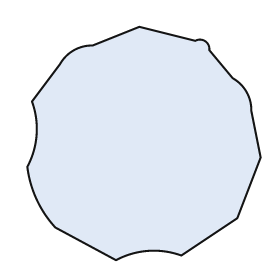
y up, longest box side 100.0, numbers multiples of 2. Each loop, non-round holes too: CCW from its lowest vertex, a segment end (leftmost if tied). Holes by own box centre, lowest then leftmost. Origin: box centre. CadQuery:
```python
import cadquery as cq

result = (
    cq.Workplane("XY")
    .moveTo(-12.0, -50.0)
    .threePointArc((2.0, -46.0), (16.0, -48.0))
    .lineTo(40.0, -32.0)
    .lineTo(50.0, -6.0)
    .lineTo(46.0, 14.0)
    .threePointArc((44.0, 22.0), (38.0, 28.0))
    .lineTo(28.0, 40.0)
    .threePointArc((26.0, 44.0), (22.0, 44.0))
    .lineTo(-2.0, 50.0)
    .lineTo(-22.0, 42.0)
    .threePointArc((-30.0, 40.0), (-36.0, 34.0))
    .lineTo(-48.0, 18.0)
    .threePointArc((-46.0, 4.0), (-50.0, -10.0))
    .threePointArc((-46.0, -24.0), (-38.0, -36.0))
    .close()
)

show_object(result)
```